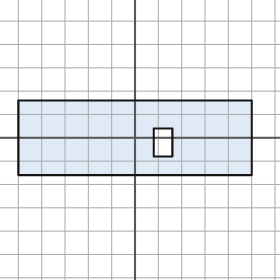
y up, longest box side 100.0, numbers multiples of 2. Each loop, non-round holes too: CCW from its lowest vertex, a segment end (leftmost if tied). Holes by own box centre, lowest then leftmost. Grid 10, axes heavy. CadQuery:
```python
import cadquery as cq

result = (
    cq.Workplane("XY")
    .moveTo(-50.0, -16.0)
    .lineTo(50.0, -16.0)
    .lineTo(50.0, 16.0)
    .lineTo(-50.0, 16.0)
    .close()
    .moveTo(8.0, -8.0)
    .lineTo(16.0, -8.0)
    .lineTo(16.0, 4.0)
    .lineTo(8.0, 4.0)
    .close()
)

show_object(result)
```